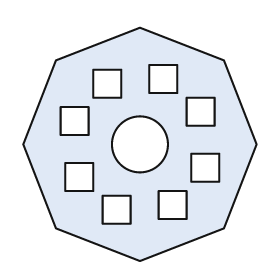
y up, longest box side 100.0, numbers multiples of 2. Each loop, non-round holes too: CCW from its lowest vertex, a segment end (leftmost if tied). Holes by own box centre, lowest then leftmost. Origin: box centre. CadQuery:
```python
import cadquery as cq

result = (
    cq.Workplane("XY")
    .moveTo(0.0, -50.0)
    .lineTo(36.0, -36.0)
    .lineTo(50.0, 0.0)
    .lineTo(36.0, 36.0)
    .lineTo(0.0, 50.0)
    .lineTo(-36.0, 36.0)
    .lineTo(-50.0, 0.0)
    .lineTo(-36.0, -36.0)
    .close()
    .moveTo(-16.0, -34.0)
    .lineTo(-4.0, -34.0)
    .lineTo(-4.0, -22.0)
    .lineTo(-16.0, -22.0)
    .close()
    .moveTo(8.0, -32.0)
    .lineTo(20.0, -32.0)
    .lineTo(20.0, -20.0)
    .lineTo(8.0, -20.0)
    .close()
    .moveTo(-32.0, -20.0)
    .lineTo(-20.0, -20.0)
    .lineTo(-20.0, -8.0)
    .lineTo(-32.0, -8.0)
    .close()
    .moveTo(22.0, -16.0)
    .lineTo(34.0, -16.0)
    .lineTo(34.0, -4.0)
    .lineTo(22.0, -4.0)
    .close()
    .moveTo(0.0, 0.0)
    .circle(12.0)
    .moveTo(-34.0, 4.0)
    .lineTo(-22.0, 4.0)
    .lineTo(-22.0, 16.0)
    .lineTo(-34.0, 16.0)
    .close()
    .moveTo(20.0, 8.0)
    .lineTo(32.0, 8.0)
    .lineTo(32.0, 20.0)
    .lineTo(20.0, 20.0)
    .close()
    .moveTo(-20.0, 20.0)
    .lineTo(-8.0, 20.0)
    .lineTo(-8.0, 32.0)
    .lineTo(-20.0, 32.0)
    .close()
    .moveTo(4.0, 22.0)
    .lineTo(16.0, 22.0)
    .lineTo(16.0, 34.0)
    .lineTo(4.0, 34.0)
    .close()
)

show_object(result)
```